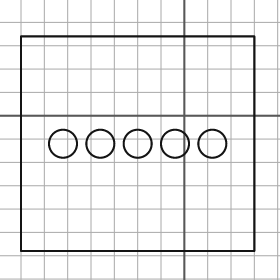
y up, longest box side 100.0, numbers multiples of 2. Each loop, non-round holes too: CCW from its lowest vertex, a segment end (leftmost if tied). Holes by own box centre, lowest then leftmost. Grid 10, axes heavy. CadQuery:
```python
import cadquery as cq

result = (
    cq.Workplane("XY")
    .moveTo(-70.0, -58.0)
    .lineTo(30.0, -58.0)
    .lineTo(30.0, 34.0)
    .lineTo(-70.0, 34.0)
    .close()
    .moveTo(-52.0, -12.0)
    .circle(6.0)
    .moveTo(-36.0, -12.0)
    .circle(6.0)
    .moveTo(-20.0, -12.0)
    .circle(6.0)
    .moveTo(-4.0, -12.0)
    .circle(6.0)
    .moveTo(12.0, -12.0)
    .circle(6.0)
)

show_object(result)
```